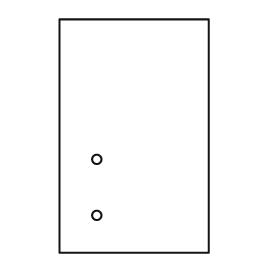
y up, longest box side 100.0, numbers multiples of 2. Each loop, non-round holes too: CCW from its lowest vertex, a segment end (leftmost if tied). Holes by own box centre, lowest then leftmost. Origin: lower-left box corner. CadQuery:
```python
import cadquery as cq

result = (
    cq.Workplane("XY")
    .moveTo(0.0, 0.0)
    .lineTo(64.0, 0.0)
    .lineTo(64.0, 100.0)
    .lineTo(0.0, 100.0)
    .close()
    .moveTo(16.0, 16.0)
    .circle(2.0)
    .moveTo(16.0, 40.0)
    .circle(2.0)
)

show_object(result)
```